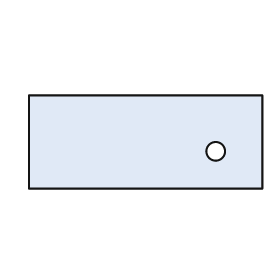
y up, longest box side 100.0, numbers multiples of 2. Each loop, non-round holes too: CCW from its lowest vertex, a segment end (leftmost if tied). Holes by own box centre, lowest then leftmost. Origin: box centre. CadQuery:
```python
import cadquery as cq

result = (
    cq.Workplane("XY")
    .moveTo(-50.0, -20.0)
    .lineTo(50.0, -20.0)
    .lineTo(50.0, 20.0)
    .lineTo(-50.0, 20.0)
    .close()
    .moveTo(30.0, -4.0)
    .circle(4.0)
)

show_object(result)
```